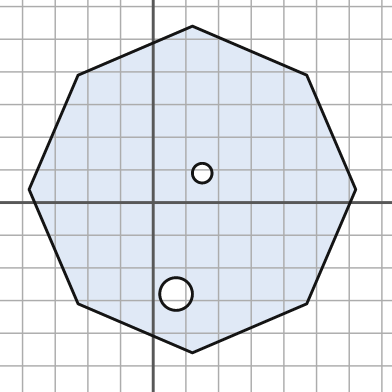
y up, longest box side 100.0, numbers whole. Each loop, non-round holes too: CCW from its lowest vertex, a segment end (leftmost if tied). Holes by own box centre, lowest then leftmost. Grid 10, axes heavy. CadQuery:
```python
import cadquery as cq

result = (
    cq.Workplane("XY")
    .moveTo(12.0, -46.0)
    .lineTo(47.0, -31.0)
    .lineTo(62.0, 4.0)
    .lineTo(47.0, 39.0)
    .lineTo(12.0, 54.0)
    .lineTo(-23.0, 39.0)
    .lineTo(-38.0, 4.0)
    .lineTo(-23.0, -31.0)
    .close()
    .moveTo(7.0, -28.0)
    .circle(5.0)
    .moveTo(15.0, 9.0)
    .circle(3.0)
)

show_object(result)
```